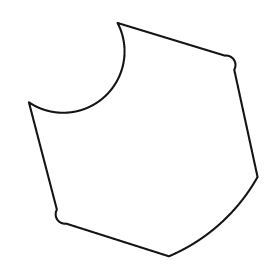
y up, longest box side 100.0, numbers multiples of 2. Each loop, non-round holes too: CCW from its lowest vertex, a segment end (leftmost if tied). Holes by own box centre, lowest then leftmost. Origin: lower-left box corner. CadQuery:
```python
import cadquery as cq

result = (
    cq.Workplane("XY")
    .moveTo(60.0, 0.0)
    .threePointArc((82.0, 14.0), (98.0, 34.0))
    .lineTo(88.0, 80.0)
    .threePointArc((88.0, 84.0), (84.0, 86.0))
    .lineTo(38.0, 100.0)
    .threePointArc((32.0, 68.0), (0.0, 66.0))
    .lineTo(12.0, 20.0)
    .threePointArc((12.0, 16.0), (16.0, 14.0))
    .close()
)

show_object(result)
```